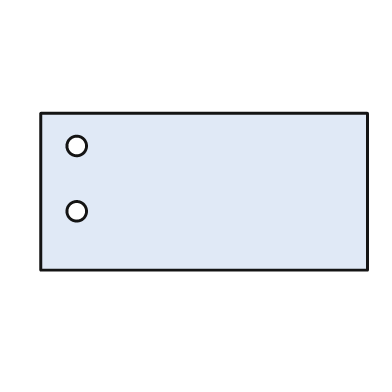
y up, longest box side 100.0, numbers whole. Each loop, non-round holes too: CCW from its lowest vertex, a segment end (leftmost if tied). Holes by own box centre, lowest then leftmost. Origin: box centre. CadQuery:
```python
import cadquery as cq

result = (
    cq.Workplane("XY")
    .moveTo(-50.0, -24.0)
    .lineTo(50.0, -24.0)
    .lineTo(50.0, 24.0)
    .lineTo(-50.0, 24.0)
    .close()
    .moveTo(-39.0, -6.0)
    .circle(3.0)
    .moveTo(-39.0, 14.0)
    .circle(3.0)
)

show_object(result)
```